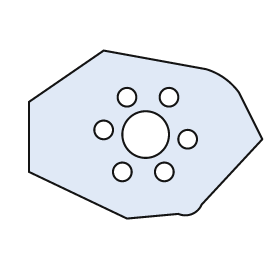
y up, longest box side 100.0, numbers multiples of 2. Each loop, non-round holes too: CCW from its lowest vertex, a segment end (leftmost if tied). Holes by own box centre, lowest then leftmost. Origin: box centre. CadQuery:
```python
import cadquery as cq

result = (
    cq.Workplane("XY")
    .moveTo(-8.0, -36.0)
    .lineTo(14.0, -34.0)
    .threePointArc((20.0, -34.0), (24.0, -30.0))
    .lineTo(50.0, -2.0)
    .lineTo(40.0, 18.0)
    .threePointArc((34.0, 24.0), (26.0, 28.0))
    .lineTo(-18.0, 36.0)
    .lineTo(-50.0, 14.0)
    .lineTo(-50.0, -16.0)
    .close()
    .moveTo(-10.0, -16.0)
    .circle(4.0)
    .moveTo(8.0, -16.0)
    .circle(4.0)
    .moveTo(18.0, -2.0)
    .circle(4.0)
    .moveTo(0.0, 0.0)
    .circle(10.0)
    .moveTo(-18.0, 2.0)
    .circle(4.0)
    .moveTo(-8.0, 16.0)
    .circle(4.0)
    .moveTo(10.0, 16.0)
    .circle(4.0)
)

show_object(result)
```